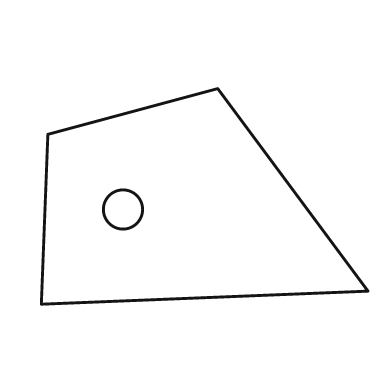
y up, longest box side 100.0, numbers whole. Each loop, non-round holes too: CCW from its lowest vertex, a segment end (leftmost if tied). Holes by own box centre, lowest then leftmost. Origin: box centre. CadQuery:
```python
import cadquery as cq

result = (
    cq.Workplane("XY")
    .moveTo(-50.0, -33.0)
    .lineTo(50.0, -29.0)
    .lineTo(4.0, 33.0)
    .lineTo(-48.0, 19.0)
    .close()
    .moveTo(-25.0, -4.0)
    .circle(6.0)
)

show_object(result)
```